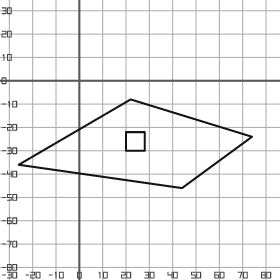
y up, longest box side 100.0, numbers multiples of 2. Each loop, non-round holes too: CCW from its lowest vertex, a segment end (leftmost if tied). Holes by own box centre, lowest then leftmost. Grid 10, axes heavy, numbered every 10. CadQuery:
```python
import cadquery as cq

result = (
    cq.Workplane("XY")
    .moveTo(44.0, -46.0)
    .lineTo(74.0, -24.0)
    .lineTo(22.0, -8.0)
    .lineTo(-26.0, -36.0)
    .close()
    .moveTo(20.0, -30.0)
    .lineTo(28.0, -30.0)
    .lineTo(28.0, -22.0)
    .lineTo(20.0, -22.0)
    .close()
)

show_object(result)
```